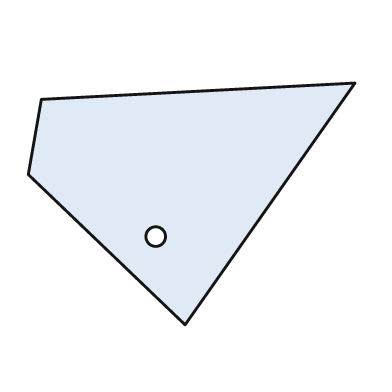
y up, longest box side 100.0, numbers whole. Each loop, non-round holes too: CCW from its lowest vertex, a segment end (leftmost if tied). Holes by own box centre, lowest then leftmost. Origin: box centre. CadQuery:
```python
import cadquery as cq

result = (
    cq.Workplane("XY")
    .moveTo(-2.0, -37.0)
    .lineTo(50.0, 37.0)
    .lineTo(-46.0, 32.0)
    .lineTo(-50.0, 9.0)
    .close()
    .moveTo(-11.0, -10.0)
    .circle(3.0)
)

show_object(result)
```